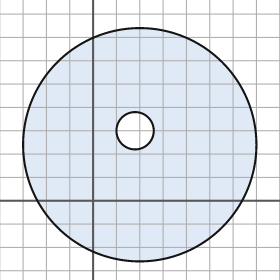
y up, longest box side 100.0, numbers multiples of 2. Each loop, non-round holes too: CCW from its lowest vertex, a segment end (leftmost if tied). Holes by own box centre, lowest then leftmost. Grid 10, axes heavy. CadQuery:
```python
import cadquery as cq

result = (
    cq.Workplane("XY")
    .moveTo(20.0, 24.0)
    .circle(50.0)
    .moveTo(18.0, 30.0)
    .circle(8.0)
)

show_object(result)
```